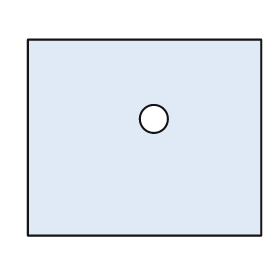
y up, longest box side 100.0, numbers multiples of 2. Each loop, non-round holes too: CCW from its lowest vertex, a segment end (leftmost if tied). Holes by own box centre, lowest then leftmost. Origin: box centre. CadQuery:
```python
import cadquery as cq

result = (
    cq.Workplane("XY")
    .moveTo(-50.0, -42.0)
    .lineTo(50.0, -42.0)
    .lineTo(50.0, 42.0)
    .lineTo(-50.0, 42.0)
    .close()
    .moveTo(4.0, 8.0)
    .circle(6.0)
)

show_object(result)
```